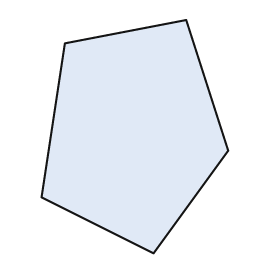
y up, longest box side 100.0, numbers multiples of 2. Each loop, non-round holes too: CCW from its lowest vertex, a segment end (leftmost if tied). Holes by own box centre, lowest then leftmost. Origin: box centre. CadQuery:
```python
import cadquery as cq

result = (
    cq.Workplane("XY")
    .moveTo(8.0, -50.0)
    .lineTo(40.0, -6.0)
    .lineTo(22.0, 50.0)
    .lineTo(-30.0, 40.0)
    .lineTo(-40.0, -26.0)
    .close()
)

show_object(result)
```